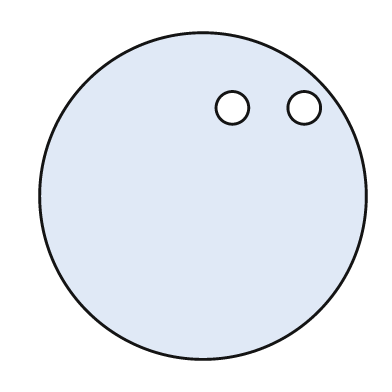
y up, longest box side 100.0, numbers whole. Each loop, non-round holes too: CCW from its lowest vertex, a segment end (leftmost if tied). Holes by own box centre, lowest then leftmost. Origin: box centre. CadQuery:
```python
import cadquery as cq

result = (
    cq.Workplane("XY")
    .moveTo(0.0, 0.0)
    .circle(50.0)
    .moveTo(9.0, 27.0)
    .circle(5.0)
    .moveTo(31.0, 27.0)
    .circle(5.0)
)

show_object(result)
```